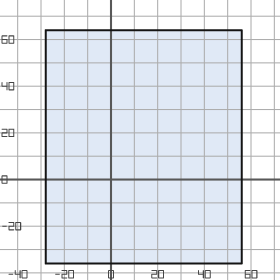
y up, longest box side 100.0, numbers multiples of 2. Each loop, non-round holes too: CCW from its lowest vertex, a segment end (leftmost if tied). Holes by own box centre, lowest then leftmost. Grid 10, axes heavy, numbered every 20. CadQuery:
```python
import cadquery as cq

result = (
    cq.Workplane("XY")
    .moveTo(-28.0, -36.0)
    .lineTo(56.0, -36.0)
    .lineTo(56.0, 64.0)
    .lineTo(-28.0, 64.0)
    .close()
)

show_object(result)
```